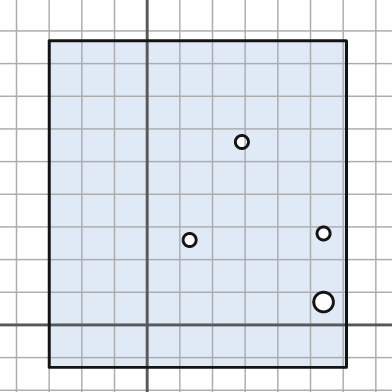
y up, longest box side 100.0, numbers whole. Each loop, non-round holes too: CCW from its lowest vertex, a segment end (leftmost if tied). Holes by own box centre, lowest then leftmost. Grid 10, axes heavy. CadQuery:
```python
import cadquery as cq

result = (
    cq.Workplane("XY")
    .moveTo(-30.0, -13.0)
    .lineTo(61.0, -13.0)
    .lineTo(61.0, 87.0)
    .lineTo(-30.0, 87.0)
    .close()
    .moveTo(54.0, 7.0)
    .circle(3.0)
    .moveTo(13.0, 26.0)
    .circle(2.0)
    .moveTo(54.0, 28.0)
    .circle(2.0)
    .moveTo(29.0, 56.0)
    .circle(2.0)
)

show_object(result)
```